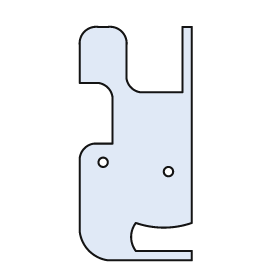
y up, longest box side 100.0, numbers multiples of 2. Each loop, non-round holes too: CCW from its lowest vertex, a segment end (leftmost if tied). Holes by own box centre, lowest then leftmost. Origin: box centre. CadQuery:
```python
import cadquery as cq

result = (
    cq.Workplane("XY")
    .moveTo(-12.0, -50.0)
    .lineTo(24.0, -50.0)
    .lineTo(24.0, -46.0)
    .lineTo(0.0, -46.0)
    .threePointArc((-2.0, -40.0), (0.0, -34.0))
    .threePointArc((12.0, -36.0), (24.0, -34.0))
    .lineTo(24.0, 50.0)
    .lineTo(20.0, 50.0)
    .lineTo(20.0, 22.0)
    .lineTo(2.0, 22.0)
    .threePointArc((-2.0, 24.0), (-4.0, 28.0))
    .lineTo(-4.0, 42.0)
    .threePointArc((-6.0, 48.0), (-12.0, 50.0))
    .lineTo(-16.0, 50.0)
    .threePointArc((-22.0, 48.0), (-24.0, 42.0))
    .lineTo(-24.0, 26.0)
    .lineTo(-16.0, 26.0)
    .threePointArc((-12.0, 24.0), (-10.0, 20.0))
    .lineTo(-10.0, 0.0)
    .lineTo(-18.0, 0.0)
    .threePointArc((-22.0, -2.0), (-24.0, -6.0))
    .lineTo(-24.0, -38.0)
    .threePointArc((-20.0, -46.0), (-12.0, -50.0))
    .close()
    .moveTo(14.0, -12.0)
    .circle(2.0)
    .moveTo(-14.0, -8.0)
    .circle(2.0)
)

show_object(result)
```